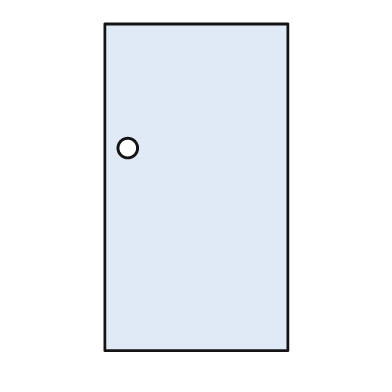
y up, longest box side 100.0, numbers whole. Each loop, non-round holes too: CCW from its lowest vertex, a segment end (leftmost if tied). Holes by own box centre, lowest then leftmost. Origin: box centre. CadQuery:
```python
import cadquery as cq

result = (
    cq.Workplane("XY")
    .moveTo(-28.0, -50.0)
    .lineTo(28.0, -50.0)
    .lineTo(28.0, 50.0)
    .lineTo(-28.0, 50.0)
    .close()
    .moveTo(-21.0, 12.0)
    .circle(3.0)
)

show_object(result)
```